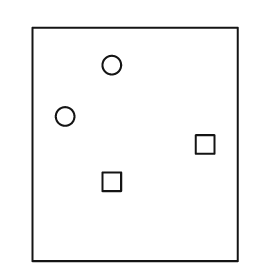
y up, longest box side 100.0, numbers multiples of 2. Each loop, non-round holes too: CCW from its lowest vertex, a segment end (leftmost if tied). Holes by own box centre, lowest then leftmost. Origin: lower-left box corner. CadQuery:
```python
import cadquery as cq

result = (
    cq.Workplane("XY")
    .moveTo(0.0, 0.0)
    .lineTo(88.0, 0.0)
    .lineTo(88.0, 100.0)
    .lineTo(0.0, 100.0)
    .close()
    .moveTo(30.0, 30.0)
    .lineTo(38.0, 30.0)
    .lineTo(38.0, 38.0)
    .lineTo(30.0, 38.0)
    .close()
    .moveTo(70.0, 46.0)
    .lineTo(78.0, 46.0)
    .lineTo(78.0, 54.0)
    .lineTo(70.0, 54.0)
    .close()
    .moveTo(14.0, 62.0)
    .circle(4.0)
    .moveTo(34.0, 84.0)
    .circle(4.0)
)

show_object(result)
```